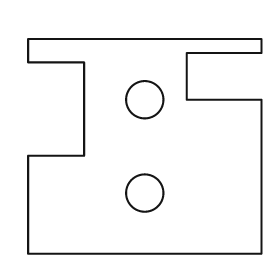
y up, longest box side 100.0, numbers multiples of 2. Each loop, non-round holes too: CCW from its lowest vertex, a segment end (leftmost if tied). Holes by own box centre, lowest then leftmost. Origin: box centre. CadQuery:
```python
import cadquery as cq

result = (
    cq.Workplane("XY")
    .moveTo(-50.0, -46.0)
    .lineTo(50.0, -46.0)
    .lineTo(50.0, 20.0)
    .lineTo(18.0, 20.0)
    .lineTo(18.0, 40.0)
    .lineTo(50.0, 40.0)
    .lineTo(50.0, 46.0)
    .lineTo(-50.0, 46.0)
    .lineTo(-50.0, 36.0)
    .lineTo(-26.0, 36.0)
    .lineTo(-26.0, -4.0)
    .lineTo(-50.0, -4.0)
    .close()
    .moveTo(0.0, -20.0)
    .circle(8.0)
    .moveTo(0.0, 20.0)
    .circle(8.0)
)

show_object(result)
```